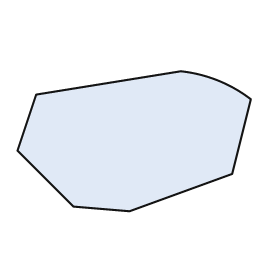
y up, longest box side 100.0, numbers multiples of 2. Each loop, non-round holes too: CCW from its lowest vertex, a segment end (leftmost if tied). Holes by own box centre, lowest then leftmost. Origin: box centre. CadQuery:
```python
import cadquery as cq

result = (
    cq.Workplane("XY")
    .moveTo(-2.0, -30.0)
    .lineTo(42.0, -14.0)
    .lineTo(50.0, 18.0)
    .threePointArc((36.0, 26.0), (20.0, 30.0))
    .lineTo(-42.0, 20.0)
    .lineTo(-50.0, -4.0)
    .lineTo(-26.0, -28.0)
    .close()
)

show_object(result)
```